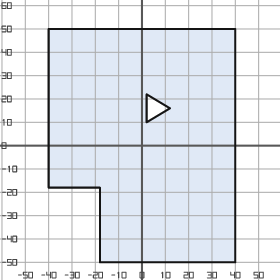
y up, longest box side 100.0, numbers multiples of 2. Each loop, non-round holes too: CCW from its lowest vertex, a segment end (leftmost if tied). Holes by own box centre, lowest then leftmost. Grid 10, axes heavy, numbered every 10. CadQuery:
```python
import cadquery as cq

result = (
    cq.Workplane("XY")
    .moveTo(-18.0, -50.0)
    .lineTo(40.0, -50.0)
    .lineTo(40.0, 50.0)
    .lineTo(-40.0, 50.0)
    .lineTo(-40.0, -18.0)
    .lineTo(-18.0, -18.0)
    .close()
    .moveTo(2.0, 10.0)
    .lineTo(12.0, 16.0)
    .lineTo(2.0, 22.0)
    .close()
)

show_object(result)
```